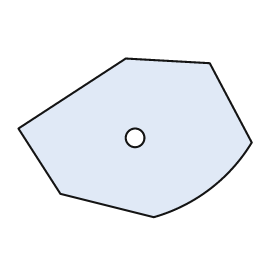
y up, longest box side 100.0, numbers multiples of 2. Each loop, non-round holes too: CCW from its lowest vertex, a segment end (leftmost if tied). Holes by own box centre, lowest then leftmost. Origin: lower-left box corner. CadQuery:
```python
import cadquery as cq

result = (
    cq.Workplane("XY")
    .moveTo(58.0, 0.0)
    .threePointArc((82.0, 12.0), (100.0, 32.0))
    .lineTo(82.0, 66.0)
    .lineTo(46.0, 68.0)
    .lineTo(0.0, 38.0)
    .lineTo(18.0, 10.0)
    .close()
    .moveTo(50.0, 34.0)
    .circle(4.0)
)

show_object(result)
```